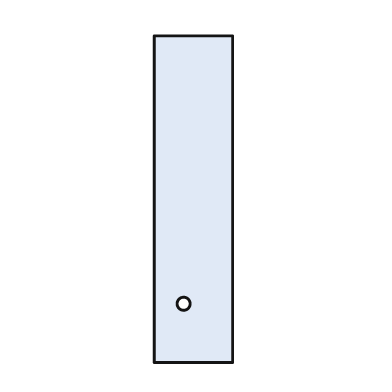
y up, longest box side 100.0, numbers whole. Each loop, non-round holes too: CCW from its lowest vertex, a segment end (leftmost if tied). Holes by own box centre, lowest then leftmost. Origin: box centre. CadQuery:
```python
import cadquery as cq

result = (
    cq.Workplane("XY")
    .moveTo(-12.0, -50.0)
    .lineTo(12.0, -50.0)
    .lineTo(12.0, 50.0)
    .lineTo(-12.0, 50.0)
    .close()
    .moveTo(-3.0, -32.0)
    .circle(2.0)
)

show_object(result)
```